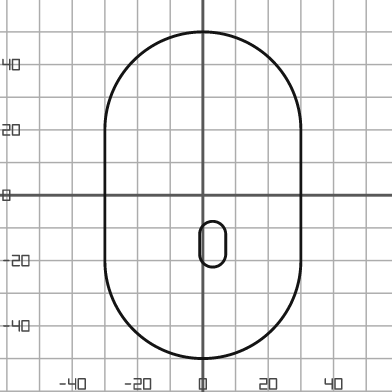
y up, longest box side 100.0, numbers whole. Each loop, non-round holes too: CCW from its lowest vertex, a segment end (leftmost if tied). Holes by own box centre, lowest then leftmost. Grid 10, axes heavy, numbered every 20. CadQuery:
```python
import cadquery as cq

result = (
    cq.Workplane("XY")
    .moveTo(-30.0, -20.0)
    .threePointArc((0.0, -50.0), (30.0, -20.0))
    .lineTo(30.0, 20.0)
    .threePointArc((0.0, 50.0), (-30.0, 20.0))
    .close()
    .moveTo(-1.0, -18.0)
    .threePointArc((3.0, -22.0), (7.0, -18.0))
    .lineTo(7.0, -12.0)
    .threePointArc((3.0, -8.0), (-1.0, -12.0))
    .close()
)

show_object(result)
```